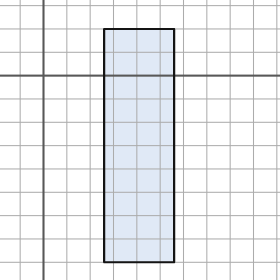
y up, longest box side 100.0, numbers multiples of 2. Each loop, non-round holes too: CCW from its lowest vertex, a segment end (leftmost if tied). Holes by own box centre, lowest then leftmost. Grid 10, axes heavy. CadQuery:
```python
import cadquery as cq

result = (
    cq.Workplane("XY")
    .moveTo(26.0, -80.0)
    .lineTo(56.0, -80.0)
    .lineTo(56.0, 20.0)
    .lineTo(26.0, 20.0)
    .close()
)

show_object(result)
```